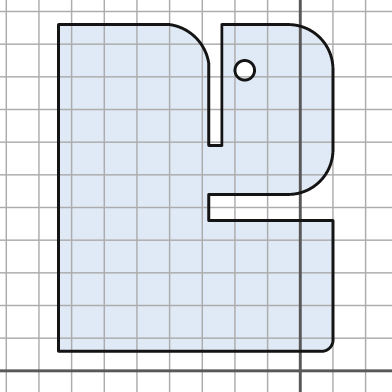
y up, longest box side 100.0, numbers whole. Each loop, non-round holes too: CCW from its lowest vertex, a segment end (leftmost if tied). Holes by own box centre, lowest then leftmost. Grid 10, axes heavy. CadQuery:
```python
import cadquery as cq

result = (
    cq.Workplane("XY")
    .moveTo(-74.0, 6.0)
    .lineTo(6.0, 6.0)
    .threePointArc((9.0, 7.0), (10.0, 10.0))
    .lineTo(10.0, 46.0)
    .lineTo(-28.0, 46.0)
    .lineTo(-28.0, 54.0)
    .lineTo(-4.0, 54.0)
    .threePointArc((6.0, 58.0), (10.0, 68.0))
    .lineTo(10.0, 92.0)
    .threePointArc((6.0, 102.0), (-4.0, 106.0))
    .lineTo(-24.0, 106.0)
    .lineTo(-24.0, 69.0)
    .lineTo(-28.0, 69.0)
    .lineTo(-28.0, 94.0)
    .threePointArc((-32.0, 102.0), (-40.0, 106.0))
    .lineTo(-74.0, 106.0)
    .close()
    .moveTo(-17.0, 92.0)
    .circle(3.0)
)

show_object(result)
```